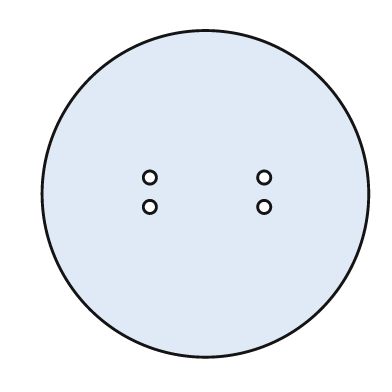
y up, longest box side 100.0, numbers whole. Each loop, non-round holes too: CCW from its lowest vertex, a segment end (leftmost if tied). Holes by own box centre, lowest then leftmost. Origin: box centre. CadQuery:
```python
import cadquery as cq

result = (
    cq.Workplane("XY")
    .moveTo(0.0, 0.0)
    .circle(50.0)
    .moveTo(-17.0, -4.0)
    .circle(2.0)
    .moveTo(18.0, -4.0)
    .circle(2.0)
    .moveTo(-17.0, 5.0)
    .circle(2.0)
    .moveTo(18.0, 5.0)
    .circle(2.0)
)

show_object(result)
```